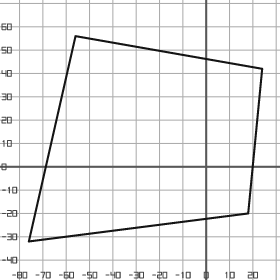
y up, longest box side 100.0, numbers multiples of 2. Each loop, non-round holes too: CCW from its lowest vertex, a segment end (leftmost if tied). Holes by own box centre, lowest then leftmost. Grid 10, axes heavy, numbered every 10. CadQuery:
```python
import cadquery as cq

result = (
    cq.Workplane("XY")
    .moveTo(-76.0, -32.0)
    .lineTo(18.0, -20.0)
    .lineTo(24.0, 42.0)
    .lineTo(-56.0, 56.0)
    .close()
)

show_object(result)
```